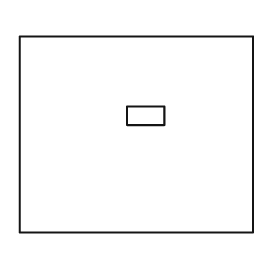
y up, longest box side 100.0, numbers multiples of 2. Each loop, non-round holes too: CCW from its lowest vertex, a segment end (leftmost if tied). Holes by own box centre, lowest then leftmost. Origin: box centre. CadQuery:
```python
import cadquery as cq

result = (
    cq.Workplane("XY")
    .moveTo(-50.0, -42.0)
    .lineTo(50.0, -42.0)
    .lineTo(50.0, 42.0)
    .lineTo(-50.0, 42.0)
    .close()
    .moveTo(-4.0, 4.0)
    .lineTo(12.0, 4.0)
    .lineTo(12.0, 12.0)
    .lineTo(-4.0, 12.0)
    .close()
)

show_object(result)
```